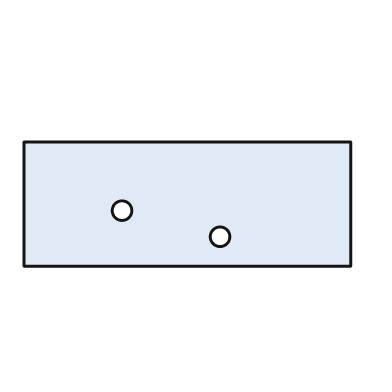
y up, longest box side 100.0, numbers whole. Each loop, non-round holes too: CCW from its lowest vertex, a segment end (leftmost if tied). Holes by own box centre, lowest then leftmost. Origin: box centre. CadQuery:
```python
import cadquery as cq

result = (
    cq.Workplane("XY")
    .moveTo(-50.0, -19.0)
    .lineTo(50.0, -19.0)
    .lineTo(50.0, 19.0)
    .lineTo(-50.0, 19.0)
    .close()
    .moveTo(10.0, -10.0)
    .circle(3.0)
    .moveTo(-20.0, -2.0)
    .circle(3.0)
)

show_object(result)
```